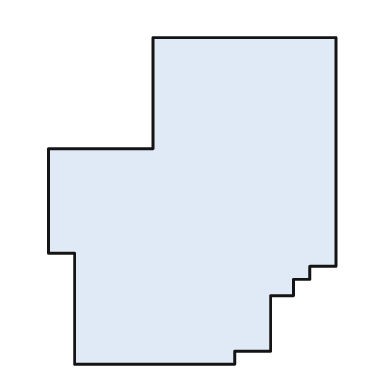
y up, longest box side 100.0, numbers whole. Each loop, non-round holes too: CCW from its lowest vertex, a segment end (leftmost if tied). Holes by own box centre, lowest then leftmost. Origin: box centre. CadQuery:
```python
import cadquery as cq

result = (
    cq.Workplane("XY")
    .moveTo(-36.0, -50.0)
    .lineTo(13.0, -50.0)
    .lineTo(13.0, -46.0)
    .lineTo(24.0, -46.0)
    .lineTo(24.0, -29.0)
    .lineTo(31.0, -29.0)
    .lineTo(31.0, -24.0)
    .lineTo(36.0, -24.0)
    .lineTo(36.0, -20.0)
    .lineTo(44.0, -20.0)
    .lineTo(44.0, 50.0)
    .lineTo(-12.0, 50.0)
    .lineTo(-12.0, 16.0)
    .lineTo(-44.0, 16.0)
    .lineTo(-44.0, -16.0)
    .lineTo(-36.0, -16.0)
    .close()
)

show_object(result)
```